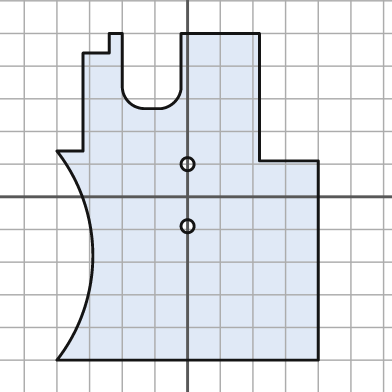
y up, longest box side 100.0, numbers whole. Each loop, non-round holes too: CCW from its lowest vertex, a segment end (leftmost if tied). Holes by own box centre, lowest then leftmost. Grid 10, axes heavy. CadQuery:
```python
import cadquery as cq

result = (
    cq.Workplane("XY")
    .moveTo(-40.0, -50.0)
    .lineTo(40.0, -50.0)
    .lineTo(40.0, 11.0)
    .lineTo(22.0, 11.0)
    .lineTo(22.0, 50.0)
    .lineTo(-2.0, 50.0)
    .lineTo(-2.0, 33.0)
    .threePointArc((-4.0, 29.0), (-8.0, 27.0))
    .lineTo(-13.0, 27.0)
    .threePointArc((-18.0, 29.0), (-20.0, 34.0))
    .lineTo(-20.0, 50.0)
    .lineTo(-24.0, 50.0)
    .lineTo(-24.0, 44.0)
    .lineTo(-32.0, 44.0)
    .lineTo(-32.0, 14.0)
    .lineTo(-40.0, 14.0)
    .threePointArc((-29.0, -18.0), (-40.0, -50.0))
    .close()
    .moveTo(0.0, -9.0)
    .circle(2.0)
    .moveTo(0.0, 10.0)
    .circle(2.0)
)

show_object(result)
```